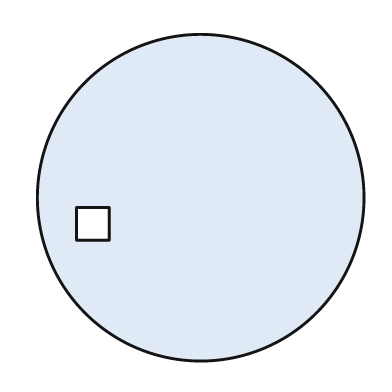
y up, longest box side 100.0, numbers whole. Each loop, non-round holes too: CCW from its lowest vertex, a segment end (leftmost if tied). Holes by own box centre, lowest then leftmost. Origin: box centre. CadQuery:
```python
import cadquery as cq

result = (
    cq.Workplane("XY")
    .moveTo(0.0, 0.0)
    .circle(50.0)
    .moveTo(-38.0, -13.0)
    .lineTo(-28.0, -13.0)
    .lineTo(-28.0, -3.0)
    .lineTo(-38.0, -3.0)
    .close()
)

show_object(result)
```